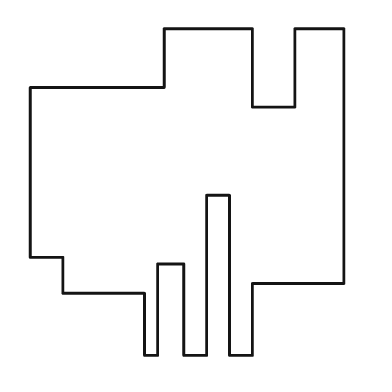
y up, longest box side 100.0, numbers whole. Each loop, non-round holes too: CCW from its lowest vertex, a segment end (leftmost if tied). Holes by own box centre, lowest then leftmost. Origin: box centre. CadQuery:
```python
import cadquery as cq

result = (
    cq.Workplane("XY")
    .moveTo(-13.0, -50.0)
    .lineTo(-9.0, -50.0)
    .lineTo(-9.0, -22.0)
    .lineTo(-1.0, -22.0)
    .lineTo(-1.0, -50.0)
    .lineTo(6.0, -50.0)
    .lineTo(6.0, -1.0)
    .lineTo(13.0, -1.0)
    .lineTo(13.0, -50.0)
    .lineTo(20.0, -50.0)
    .lineTo(20.0, -28.0)
    .lineTo(48.0, -28.0)
    .lineTo(48.0, 50.0)
    .lineTo(33.0, 50.0)
    .lineTo(33.0, 26.0)
    .lineTo(20.0, 26.0)
    .lineTo(20.0, 50.0)
    .lineTo(-7.0, 50.0)
    .lineTo(-7.0, 32.0)
    .lineTo(-48.0, 32.0)
    .lineTo(-48.0, -20.0)
    .lineTo(-38.0, -20.0)
    .lineTo(-38.0, -31.0)
    .lineTo(-13.0, -31.0)
    .close()
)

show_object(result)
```